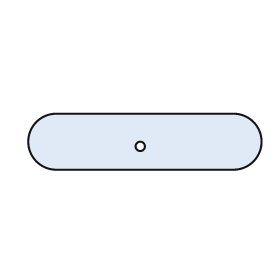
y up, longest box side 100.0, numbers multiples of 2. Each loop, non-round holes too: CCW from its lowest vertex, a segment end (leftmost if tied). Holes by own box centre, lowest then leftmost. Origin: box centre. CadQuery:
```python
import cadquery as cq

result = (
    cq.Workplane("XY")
    .moveTo(-38.0, -12.0)
    .lineTo(38.0, -12.0)
    .threePointArc((50.0, 0.0), (38.0, 12.0))
    .lineTo(-38.0, 12.0)
    .threePointArc((-50.0, 0.0), (-38.0, -12.0))
    .close()
    .moveTo(-2.0, -2.0)
    .circle(2.0)
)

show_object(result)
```